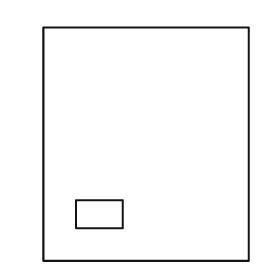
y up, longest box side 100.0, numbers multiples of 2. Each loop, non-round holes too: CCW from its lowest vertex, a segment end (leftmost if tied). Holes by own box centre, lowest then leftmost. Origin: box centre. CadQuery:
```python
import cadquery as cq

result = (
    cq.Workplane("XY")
    .moveTo(-44.0, -50.0)
    .lineTo(44.0, -50.0)
    .lineTo(44.0, 50.0)
    .lineTo(-44.0, 50.0)
    .close()
    .moveTo(-30.0, -36.0)
    .lineTo(-10.0, -36.0)
    .lineTo(-10.0, -24.0)
    .lineTo(-30.0, -24.0)
    .close()
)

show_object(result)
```